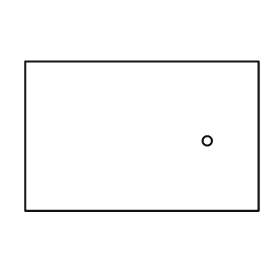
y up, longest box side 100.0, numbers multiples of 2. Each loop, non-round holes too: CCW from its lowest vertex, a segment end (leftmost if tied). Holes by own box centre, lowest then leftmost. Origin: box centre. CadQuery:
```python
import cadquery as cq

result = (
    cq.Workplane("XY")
    .moveTo(-50.0, -32.0)
    .lineTo(50.0, -32.0)
    .lineTo(50.0, 32.0)
    .lineTo(-50.0, 32.0)
    .close()
    .moveTo(28.0, -2.0)
    .circle(2.0)
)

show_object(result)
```